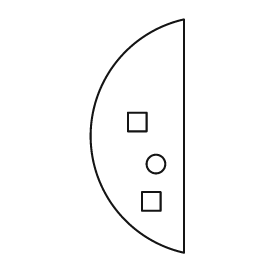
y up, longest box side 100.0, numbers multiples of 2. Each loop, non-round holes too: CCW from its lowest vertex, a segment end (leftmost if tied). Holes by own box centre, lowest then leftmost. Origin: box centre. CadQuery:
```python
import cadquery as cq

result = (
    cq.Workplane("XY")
    .moveTo(20.0, -50.0)
    .lineTo(20.0, 50.0)
    .threePointArc((-20.0, 0.0), (20.0, -50.0))
    .close()
    .moveTo(2.0, -32.0)
    .lineTo(10.0, -32.0)
    .lineTo(10.0, -24.0)
    .lineTo(2.0, -24.0)
    .close()
    .moveTo(8.0, -12.0)
    .circle(4.0)
    .moveTo(-4.0, 2.0)
    .lineTo(4.0, 2.0)
    .lineTo(4.0, 10.0)
    .lineTo(-4.0, 10.0)
    .close()
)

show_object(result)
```